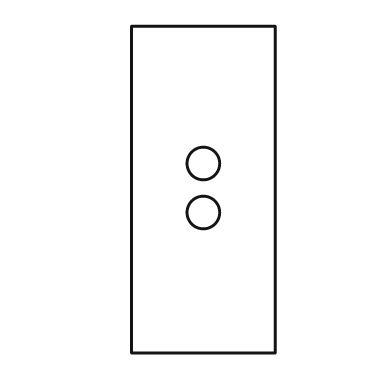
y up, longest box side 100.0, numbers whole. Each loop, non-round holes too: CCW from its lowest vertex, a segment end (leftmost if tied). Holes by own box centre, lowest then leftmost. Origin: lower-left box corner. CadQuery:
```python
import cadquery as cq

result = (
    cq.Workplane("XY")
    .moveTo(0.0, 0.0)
    .lineTo(44.0, 0.0)
    .lineTo(44.0, 100.0)
    .lineTo(0.0, 100.0)
    .close()
    .moveTo(22.0, 43.0)
    .circle(5.0)
    .moveTo(22.0, 58.0)
    .circle(5.0)
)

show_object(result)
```